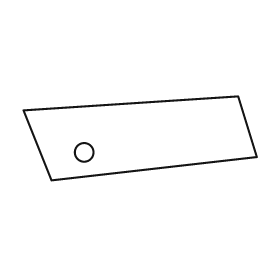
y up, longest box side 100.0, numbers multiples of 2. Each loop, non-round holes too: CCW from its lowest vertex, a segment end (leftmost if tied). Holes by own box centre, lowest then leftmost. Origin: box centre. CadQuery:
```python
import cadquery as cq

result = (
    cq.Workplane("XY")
    .moveTo(-38.0, -18.0)
    .lineTo(50.0, -8.0)
    .lineTo(42.0, 18.0)
    .lineTo(-50.0, 12.0)
    .close()
    .moveTo(-24.0, -6.0)
    .circle(4.0)
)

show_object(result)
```